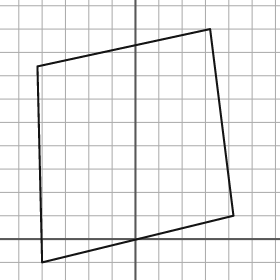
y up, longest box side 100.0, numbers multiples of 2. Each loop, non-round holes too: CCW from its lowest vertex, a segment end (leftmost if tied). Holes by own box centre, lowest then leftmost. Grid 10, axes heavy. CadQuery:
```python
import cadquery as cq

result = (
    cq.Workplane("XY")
    .moveTo(-40.0, -10.0)
    .lineTo(42.0, 10.0)
    .lineTo(32.0, 90.0)
    .lineTo(-42.0, 74.0)
    .close()
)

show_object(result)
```